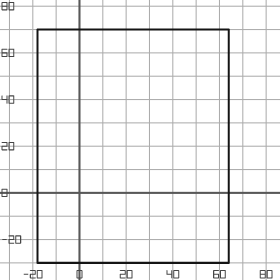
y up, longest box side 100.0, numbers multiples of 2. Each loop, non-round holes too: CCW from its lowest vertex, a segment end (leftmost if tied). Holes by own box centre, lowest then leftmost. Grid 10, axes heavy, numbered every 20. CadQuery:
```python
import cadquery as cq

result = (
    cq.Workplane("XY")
    .moveTo(-18.0, -30.0)
    .lineTo(64.0, -30.0)
    .lineTo(64.0, 70.0)
    .lineTo(-18.0, 70.0)
    .close()
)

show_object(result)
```